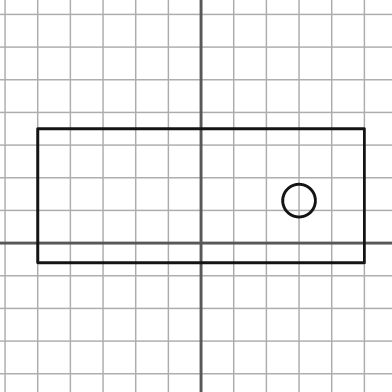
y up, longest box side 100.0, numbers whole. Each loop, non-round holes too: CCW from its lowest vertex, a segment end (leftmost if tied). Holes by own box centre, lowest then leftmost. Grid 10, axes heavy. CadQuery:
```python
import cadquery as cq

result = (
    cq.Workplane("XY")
    .moveTo(-50.0, -6.0)
    .lineTo(50.0, -6.0)
    .lineTo(50.0, 35.0)
    .lineTo(-50.0, 35.0)
    .close()
    .moveTo(30.0, 13.0)
    .circle(5.0)
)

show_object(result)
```